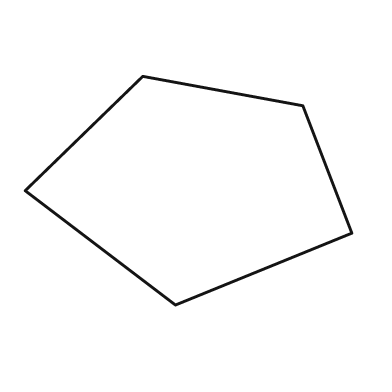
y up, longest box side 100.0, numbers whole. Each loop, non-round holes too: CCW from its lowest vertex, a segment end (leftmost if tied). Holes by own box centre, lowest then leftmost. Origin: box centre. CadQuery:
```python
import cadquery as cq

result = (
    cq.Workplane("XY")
    .moveTo(-4.0, -35.0)
    .lineTo(50.0, -13.0)
    .lineTo(35.0, 26.0)
    .lineTo(-14.0, 35.0)
    .lineTo(-50.0, 0.0)
    .close()
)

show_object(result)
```